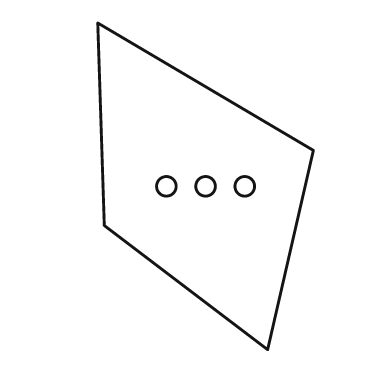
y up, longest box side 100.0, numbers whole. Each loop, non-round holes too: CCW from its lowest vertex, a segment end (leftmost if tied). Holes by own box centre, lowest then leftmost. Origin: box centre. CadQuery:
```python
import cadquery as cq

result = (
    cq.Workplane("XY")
    .moveTo(19.0, -50.0)
    .lineTo(33.0, 11.0)
    .lineTo(-33.0, 50.0)
    .lineTo(-31.0, -12.0)
    .close()
    .moveTo(-12.0, 0.0)
    .circle(3.0)
    .moveTo(0.0, 0.0)
    .circle(3.0)
    .moveTo(12.0, 0.0)
    .circle(3.0)
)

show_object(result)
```